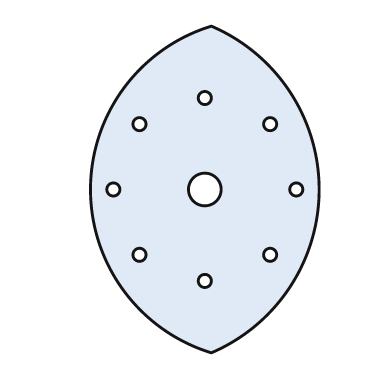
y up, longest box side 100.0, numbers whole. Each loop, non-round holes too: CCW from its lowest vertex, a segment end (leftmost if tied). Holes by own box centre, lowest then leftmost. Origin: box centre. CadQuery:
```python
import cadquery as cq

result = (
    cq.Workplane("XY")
    .moveTo(2.0, -50.0)
    .threePointArc((35.0, 0.0), (2.0, 50.0))
    .threePointArc((-35.0, 0.0), (2.0, -50.0))
    .close()
    .moveTo(0.0, -28.0)
    .circle(2.0)
    .moveTo(-20.0, -20.0)
    .circle(2.0)
    .moveTo(20.0, -20.0)
    .circle(2.0)
    .moveTo(-28.0, 0.0)
    .circle(2.0)
    .moveTo(0.0, 0.0)
    .circle(5.0)
    .moveTo(28.0, 0.0)
    .circle(2.0)
    .moveTo(-20.0, 20.0)
    .circle(2.0)
    .moveTo(20.0, 20.0)
    .circle(2.0)
    .moveTo(0.0, 28.0)
    .circle(2.0)
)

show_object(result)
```